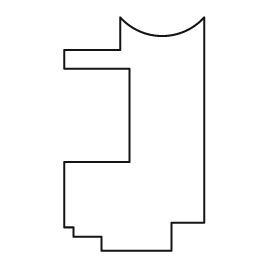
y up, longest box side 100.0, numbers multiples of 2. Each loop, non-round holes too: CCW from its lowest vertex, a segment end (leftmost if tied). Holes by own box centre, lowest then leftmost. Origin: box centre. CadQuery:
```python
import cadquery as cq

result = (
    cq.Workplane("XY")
    .moveTo(-14.0, -50.0)
    .lineTo(16.0, -50.0)
    .lineTo(16.0, -38.0)
    .lineTo(30.0, -38.0)
    .lineTo(30.0, 50.0)
    .threePointArc((12.0, 42.0), (-6.0, 50.0))
    .lineTo(-6.0, 36.0)
    .lineTo(-30.0, 36.0)
    .lineTo(-30.0, 28.0)
    .lineTo(-2.0, 28.0)
    .lineTo(-2.0, -12.0)
    .lineTo(-30.0, -12.0)
    .lineTo(-30.0, -40.0)
    .lineTo(-26.0, -40.0)
    .lineTo(-26.0, -44.0)
    .lineTo(-14.0, -44.0)
    .close()
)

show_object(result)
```